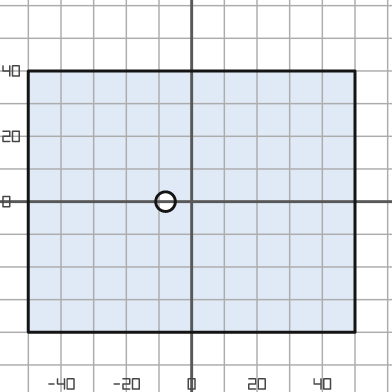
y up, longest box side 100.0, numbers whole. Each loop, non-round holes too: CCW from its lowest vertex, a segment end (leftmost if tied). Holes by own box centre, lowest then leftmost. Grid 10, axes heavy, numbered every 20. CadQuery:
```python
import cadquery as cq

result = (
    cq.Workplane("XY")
    .moveTo(-50.0, -40.0)
    .lineTo(50.0, -40.0)
    .lineTo(50.0, 40.0)
    .lineTo(-50.0, 40.0)
    .close()
    .moveTo(-8.0, 0.0)
    .circle(3.0)
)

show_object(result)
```